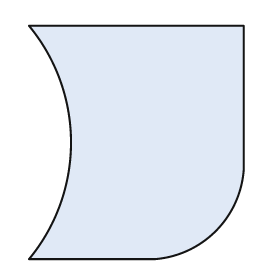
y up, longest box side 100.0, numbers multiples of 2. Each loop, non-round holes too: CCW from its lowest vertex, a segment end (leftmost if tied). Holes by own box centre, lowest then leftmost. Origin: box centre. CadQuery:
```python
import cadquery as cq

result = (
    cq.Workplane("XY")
    .moveTo(-46.0, -50.0)
    .lineTo(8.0, -50.0)
    .threePointArc((34.0, -38.0), (46.0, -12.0))
    .lineTo(46.0, 50.0)
    .lineTo(-46.0, 50.0)
    .threePointArc((-28.0, 0.0), (-46.0, -50.0))
    .close()
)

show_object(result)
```